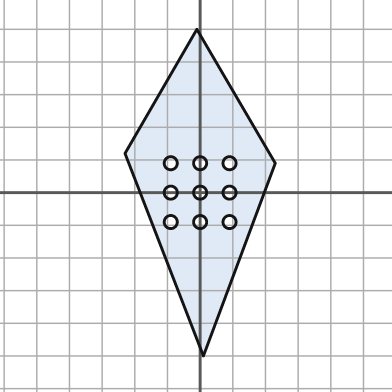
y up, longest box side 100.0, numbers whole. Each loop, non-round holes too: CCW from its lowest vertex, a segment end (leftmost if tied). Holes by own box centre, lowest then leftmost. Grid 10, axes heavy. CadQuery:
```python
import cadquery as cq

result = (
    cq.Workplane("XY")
    .moveTo(1.0, -50.0)
    .lineTo(23.0, 9.0)
    .lineTo(-1.0, 50.0)
    .lineTo(-23.0, 12.0)
    .close()
    .moveTo(-9.0, -9.0)
    .circle(2.0)
    .moveTo(0.0, -9.0)
    .circle(2.0)
    .moveTo(9.0, -9.0)
    .circle(2.0)
    .moveTo(-9.0, 0.0)
    .circle(2.0)
    .moveTo(0.0, 0.0)
    .circle(2.0)
    .moveTo(9.0, 0.0)
    .circle(2.0)
    .moveTo(-9.0, 9.0)
    .circle(2.0)
    .moveTo(0.0, 9.0)
    .circle(2.0)
    .moveTo(9.0, 9.0)
    .circle(2.0)
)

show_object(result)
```